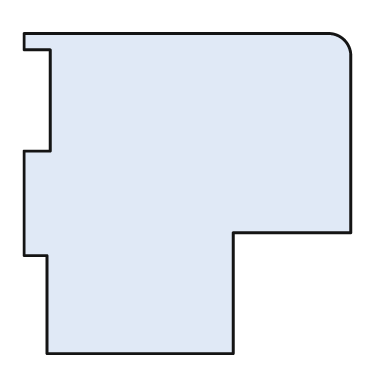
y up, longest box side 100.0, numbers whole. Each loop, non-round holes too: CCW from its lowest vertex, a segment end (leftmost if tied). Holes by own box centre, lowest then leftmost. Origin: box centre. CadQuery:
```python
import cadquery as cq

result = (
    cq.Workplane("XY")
    .moveTo(-43.0, -49.0)
    .lineTo(14.0, -49.0)
    .lineTo(14.0, -12.0)
    .lineTo(50.0, -12.0)
    .lineTo(50.0, 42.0)
    .threePointArc((48.0, 47.0), (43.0, 49.0))
    .lineTo(-50.0, 49.0)
    .lineTo(-50.0, 44.0)
    .lineTo(-42.0, 44.0)
    .lineTo(-42.0, 13.0)
    .lineTo(-50.0, 13.0)
    .lineTo(-50.0, -19.0)
    .lineTo(-43.0, -19.0)
    .close()
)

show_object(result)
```